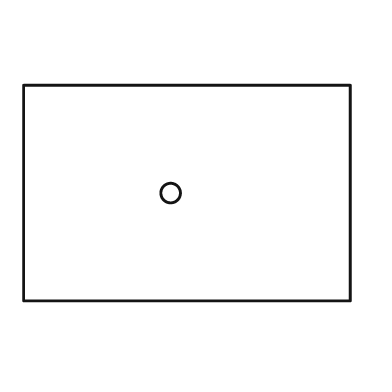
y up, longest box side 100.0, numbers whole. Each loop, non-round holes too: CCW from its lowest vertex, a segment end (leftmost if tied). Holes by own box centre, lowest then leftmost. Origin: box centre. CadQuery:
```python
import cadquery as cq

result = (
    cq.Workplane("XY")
    .moveTo(-50.0, -33.0)
    .lineTo(50.0, -33.0)
    .lineTo(50.0, 33.0)
    .lineTo(-50.0, 33.0)
    .close()
    .moveTo(-5.0, 0.0)
    .circle(3.0)
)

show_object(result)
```